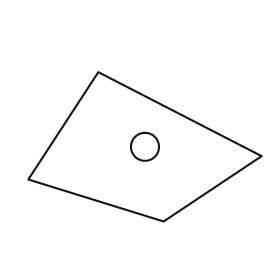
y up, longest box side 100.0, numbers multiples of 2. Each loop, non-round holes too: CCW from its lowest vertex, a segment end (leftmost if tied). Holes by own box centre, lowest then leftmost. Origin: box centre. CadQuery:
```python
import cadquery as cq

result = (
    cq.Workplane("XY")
    .moveTo(8.0, -32.0)
    .lineTo(50.0, -4.0)
    .lineTo(-20.0, 32.0)
    .lineTo(-50.0, -14.0)
    .close()
    .moveTo(0.0, 0.0)
    .circle(6.0)
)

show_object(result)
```